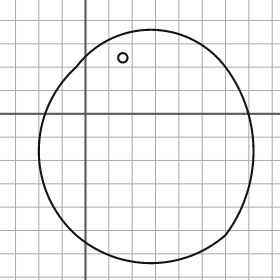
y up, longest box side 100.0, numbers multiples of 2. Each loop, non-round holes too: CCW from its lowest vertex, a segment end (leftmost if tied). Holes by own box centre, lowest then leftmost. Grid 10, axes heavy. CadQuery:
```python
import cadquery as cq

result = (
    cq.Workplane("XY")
    .moveTo(-4.0, -52.0)
    .threePointArc((28.0, -64.0), (60.0, -52.0))
    .threePointArc((72.0, -16.0), (60.0, 20.0))
    .threePointArc((28.0, 36.0), (-4.0, 20.0))
    .threePointArc((-20.0, -16.0), (-4.0, -52.0))
    .close()
    .moveTo(16.0, 24.0)
    .circle(2.0)
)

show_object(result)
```